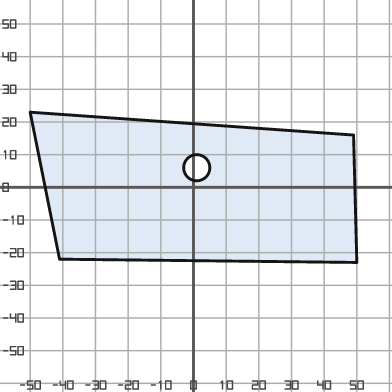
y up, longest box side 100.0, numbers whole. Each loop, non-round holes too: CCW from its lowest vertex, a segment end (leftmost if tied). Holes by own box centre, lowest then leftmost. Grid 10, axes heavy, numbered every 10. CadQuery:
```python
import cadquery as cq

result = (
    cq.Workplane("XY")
    .moveTo(50.0, -23.0)
    .lineTo(49.0, 16.0)
    .lineTo(-50.0, 23.0)
    .lineTo(-41.0, -22.0)
    .close()
    .moveTo(1.0, 6.0)
    .circle(4.0)
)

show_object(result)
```